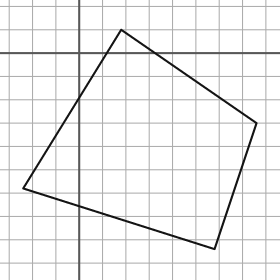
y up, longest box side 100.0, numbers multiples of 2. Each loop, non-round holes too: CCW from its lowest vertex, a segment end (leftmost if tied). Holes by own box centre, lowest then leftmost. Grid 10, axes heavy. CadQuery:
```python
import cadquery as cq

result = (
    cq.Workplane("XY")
    .moveTo(58.0, -84.0)
    .lineTo(76.0, -30.0)
    .lineTo(18.0, 10.0)
    .lineTo(-24.0, -58.0)
    .close()
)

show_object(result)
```